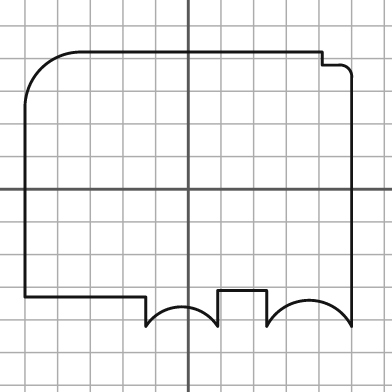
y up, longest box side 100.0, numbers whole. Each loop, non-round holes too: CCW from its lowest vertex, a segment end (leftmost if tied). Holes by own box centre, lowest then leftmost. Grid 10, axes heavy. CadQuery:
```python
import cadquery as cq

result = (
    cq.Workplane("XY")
    .moveTo(-13.0, -42.0)
    .threePointArc((-2.0, -36.0), (9.0, -42.0))
    .lineTo(9.0, -31.0)
    .lineTo(24.0, -31.0)
    .lineTo(24.0, -42.0)
    .threePointArc((37.0, -34.0), (50.0, -42.0))
    .lineTo(50.0, 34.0)
    .threePointArc((49.0, 37.0), (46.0, 38.0))
    .lineTo(41.0, 38.0)
    .lineTo(41.0, 42.0)
    .lineTo(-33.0, 42.0)
    .threePointArc((-45.0, 37.0), (-50.0, 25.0))
    .lineTo(-50.0, -33.0)
    .lineTo(-13.0, -33.0)
    .close()
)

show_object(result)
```